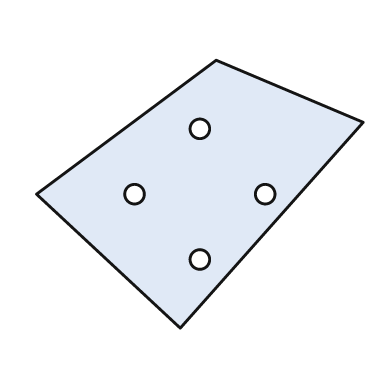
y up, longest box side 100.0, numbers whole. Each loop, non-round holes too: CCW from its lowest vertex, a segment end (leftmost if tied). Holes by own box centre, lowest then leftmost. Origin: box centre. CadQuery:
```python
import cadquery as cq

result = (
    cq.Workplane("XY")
    .moveTo(-6.0, -41.0)
    .lineTo(50.0, 22.0)
    .lineTo(5.0, 41.0)
    .lineTo(-50.0, 0.0)
    .close()
    .moveTo(0.0, -20.0)
    .circle(3.0)
    .moveTo(-20.0, 0.0)
    .circle(3.0)
    .moveTo(20.0, 0.0)
    .circle(3.0)
    .moveTo(0.0, 20.0)
    .circle(3.0)
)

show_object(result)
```